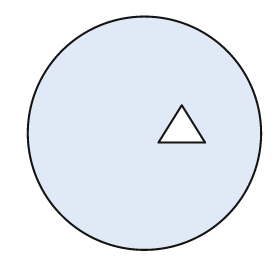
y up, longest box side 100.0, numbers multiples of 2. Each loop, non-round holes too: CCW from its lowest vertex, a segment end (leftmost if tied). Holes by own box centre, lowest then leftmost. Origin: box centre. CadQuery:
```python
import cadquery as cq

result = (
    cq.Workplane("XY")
    .moveTo(0.0, 0.0)
    .circle(50.0)
    .moveTo(6.0, -4.0)
    .lineTo(26.0, -4.0)
    .lineTo(16.0, 12.0)
    .close()
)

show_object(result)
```